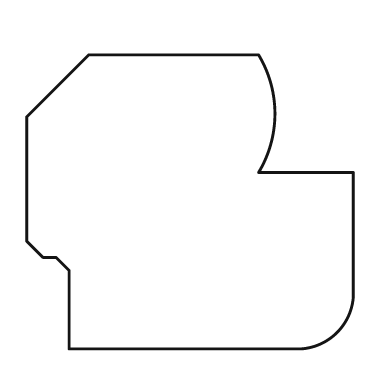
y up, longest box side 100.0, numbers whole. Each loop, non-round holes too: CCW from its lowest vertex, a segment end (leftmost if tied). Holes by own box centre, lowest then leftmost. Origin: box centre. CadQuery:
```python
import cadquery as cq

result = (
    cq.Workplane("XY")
    .moveTo(-37.0, -45.0)
    .lineTo(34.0, -45.0)
    .threePointArc((45.0, -40.0), (50.0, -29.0))
    .lineTo(50.0, 9.0)
    .lineTo(21.0, 9.0)
    .threePointArc((26.0, 27.0), (21.0, 45.0))
    .lineTo(-31.0, 45.0)
    .lineTo(-50.0, 26.0)
    .lineTo(-50.0, -12.0)
    .lineTo(-45.0, -17.0)
    .lineTo(-41.0, -17.0)
    .lineTo(-37.0, -21.0)
    .close()
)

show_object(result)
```